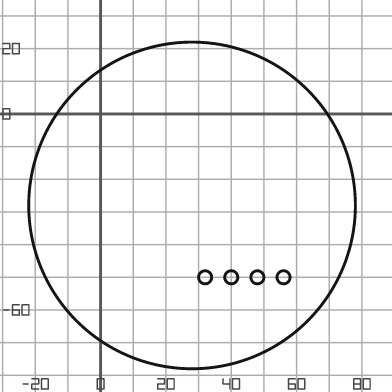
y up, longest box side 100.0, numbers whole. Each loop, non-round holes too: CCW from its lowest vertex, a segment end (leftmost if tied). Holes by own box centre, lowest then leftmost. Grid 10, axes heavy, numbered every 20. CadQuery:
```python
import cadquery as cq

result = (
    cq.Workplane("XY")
    .moveTo(28.0, -28.0)
    .circle(50.0)
    .moveTo(32.0, -50.0)
    .circle(2.0)
    .moveTo(40.0, -50.0)
    .circle(2.0)
    .moveTo(48.0, -50.0)
    .circle(2.0)
    .moveTo(56.0, -50.0)
    .circle(2.0)
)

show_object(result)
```